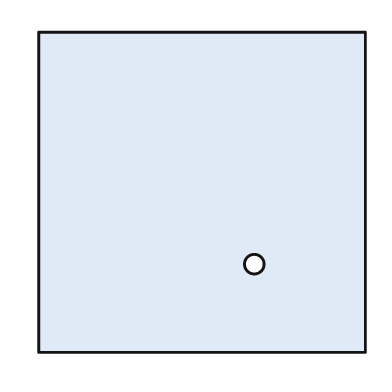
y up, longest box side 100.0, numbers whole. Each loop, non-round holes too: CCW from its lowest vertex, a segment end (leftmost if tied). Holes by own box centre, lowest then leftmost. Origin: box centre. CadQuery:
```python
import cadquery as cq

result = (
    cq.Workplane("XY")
    .moveTo(-50.0, -49.0)
    .lineTo(50.0, -49.0)
    .lineTo(50.0, 49.0)
    .lineTo(-50.0, 49.0)
    .close()
    .moveTo(16.0, -22.0)
    .circle(3.0)
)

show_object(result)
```